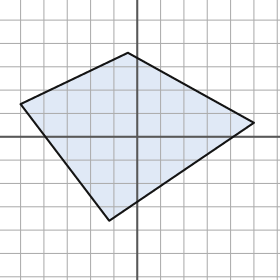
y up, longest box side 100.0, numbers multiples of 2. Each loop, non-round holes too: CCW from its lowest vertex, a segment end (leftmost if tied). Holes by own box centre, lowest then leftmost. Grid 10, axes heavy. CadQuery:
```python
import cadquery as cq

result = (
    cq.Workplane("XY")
    .moveTo(-12.0, -36.0)
    .lineTo(50.0, 6.0)
    .lineTo(-4.0, 36.0)
    .lineTo(-50.0, 14.0)
    .close()
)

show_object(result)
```